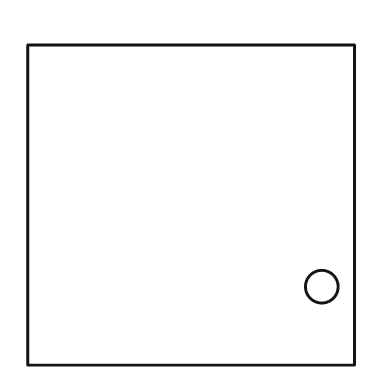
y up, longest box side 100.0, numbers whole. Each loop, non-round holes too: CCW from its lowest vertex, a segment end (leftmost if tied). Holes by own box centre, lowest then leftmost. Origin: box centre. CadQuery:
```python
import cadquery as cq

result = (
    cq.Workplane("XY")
    .moveTo(-50.0, -49.0)
    .lineTo(50.0, -49.0)
    .lineTo(50.0, 49.0)
    .lineTo(-50.0, 49.0)
    .close()
    .moveTo(40.0, -25.0)
    .circle(5.0)
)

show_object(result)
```